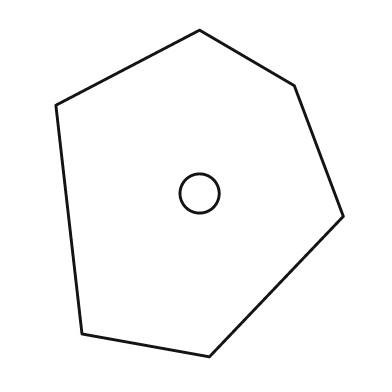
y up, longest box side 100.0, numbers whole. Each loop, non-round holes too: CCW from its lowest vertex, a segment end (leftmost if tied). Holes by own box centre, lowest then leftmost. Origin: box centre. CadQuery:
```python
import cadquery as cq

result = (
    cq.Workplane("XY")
    .moveTo(3.0, -50.0)
    .lineTo(44.0, -7.0)
    .lineTo(29.0, 33.0)
    .lineTo(0.0, 50.0)
    .lineTo(-44.0, 27.0)
    .lineTo(-36.0, -43.0)
    .close()
    .moveTo(0.0, 0.0)
    .circle(6.0)
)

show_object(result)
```